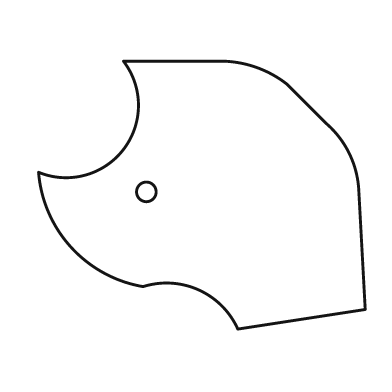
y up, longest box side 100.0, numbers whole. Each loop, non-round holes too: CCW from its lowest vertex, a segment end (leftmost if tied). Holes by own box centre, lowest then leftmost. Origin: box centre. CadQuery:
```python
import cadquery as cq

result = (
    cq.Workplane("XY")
    .moveTo(11.0, -41.0)
    .lineTo(50.0, -35.0)
    .lineTo(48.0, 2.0)
    .threePointArc((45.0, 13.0), (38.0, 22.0))
    .lineTo(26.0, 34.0)
    .threePointArc((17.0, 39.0), (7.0, 41.0))
    .lineTo(-24.0, 41.0)
    .threePointArc((-24.0, 14.0), (-50.0, 7.0))
    .threePointArc((-40.0, -16.0), (-18.0, -28.0))
    .threePointArc((-1.0, -29.0), (11.0, -41.0))
    .close()
    .moveTo(-17.0, 1.0)
    .circle(3.0)
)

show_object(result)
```